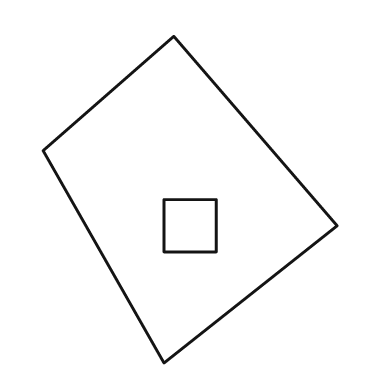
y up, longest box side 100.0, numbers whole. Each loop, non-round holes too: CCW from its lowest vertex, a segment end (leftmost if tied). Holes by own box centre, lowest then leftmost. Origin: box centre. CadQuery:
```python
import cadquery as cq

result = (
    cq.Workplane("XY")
    .moveTo(-8.0, -50.0)
    .lineTo(45.0, -8.0)
    .lineTo(-5.0, 50.0)
    .lineTo(-45.0, 15.0)
    .close()
    .moveTo(-8.0, -16.0)
    .lineTo(8.0, -16.0)
    .lineTo(8.0, 0.0)
    .lineTo(-8.0, 0.0)
    .close()
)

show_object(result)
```